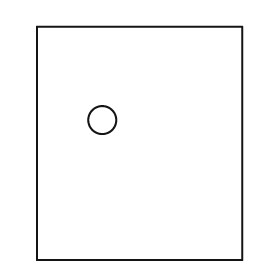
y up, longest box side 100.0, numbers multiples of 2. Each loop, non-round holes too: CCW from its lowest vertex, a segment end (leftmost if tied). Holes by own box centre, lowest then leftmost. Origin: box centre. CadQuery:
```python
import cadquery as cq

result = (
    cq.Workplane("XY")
    .moveTo(-44.0, -50.0)
    .lineTo(44.0, -50.0)
    .lineTo(44.0, 50.0)
    .lineTo(-44.0, 50.0)
    .close()
    .moveTo(-16.0, 10.0)
    .circle(6.0)
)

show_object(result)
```